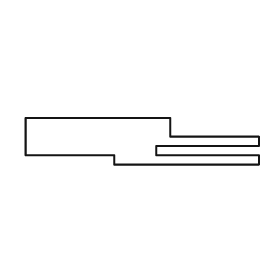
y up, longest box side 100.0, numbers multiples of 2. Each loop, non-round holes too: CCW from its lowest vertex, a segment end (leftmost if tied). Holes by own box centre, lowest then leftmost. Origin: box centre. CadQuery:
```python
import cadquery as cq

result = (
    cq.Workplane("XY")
    .moveTo(-12.0, -10.0)
    .lineTo(50.0, -10.0)
    .lineTo(50.0, -6.0)
    .lineTo(6.0, -6.0)
    .lineTo(6.0, -2.0)
    .lineTo(50.0, -2.0)
    .lineTo(50.0, 2.0)
    .lineTo(12.0, 2.0)
    .lineTo(12.0, 10.0)
    .lineTo(-50.0, 10.0)
    .lineTo(-50.0, -6.0)
    .lineTo(-12.0, -6.0)
    .close()
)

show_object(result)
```